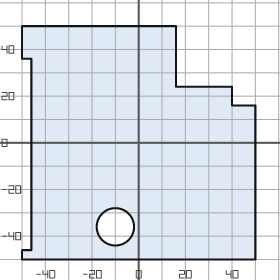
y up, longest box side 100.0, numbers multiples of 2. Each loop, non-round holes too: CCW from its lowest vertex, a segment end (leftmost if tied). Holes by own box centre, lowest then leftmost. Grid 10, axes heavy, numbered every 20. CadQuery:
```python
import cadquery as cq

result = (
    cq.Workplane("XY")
    .moveTo(-50.0, -50.0)
    .lineTo(50.0, -50.0)
    .lineTo(50.0, 16.0)
    .lineTo(40.0, 16.0)
    .lineTo(40.0, 24.0)
    .lineTo(16.0, 24.0)
    .lineTo(16.0, 50.0)
    .lineTo(-50.0, 50.0)
    .lineTo(-50.0, 36.0)
    .lineTo(-46.0, 36.0)
    .lineTo(-46.0, -46.0)
    .lineTo(-50.0, -46.0)
    .close()
    .moveTo(-10.0, -36.0)
    .circle(8.0)
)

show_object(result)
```